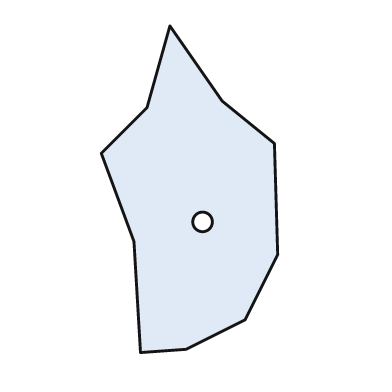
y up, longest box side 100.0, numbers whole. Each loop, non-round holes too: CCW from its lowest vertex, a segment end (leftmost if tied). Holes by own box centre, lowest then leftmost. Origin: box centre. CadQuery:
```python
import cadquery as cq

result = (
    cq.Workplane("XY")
    .moveTo(-15.0, -50.0)
    .lineTo(-1.0, -49.0)
    .lineTo(17.0, -40.0)
    .lineTo(27.0, -20.0)
    .lineTo(26.0, 14.0)
    .lineTo(10.0, 27.0)
    .lineTo(-6.0, 50.0)
    .lineTo(-13.0, 25.0)
    .lineTo(-27.0, 11.0)
    .lineTo(-17.0, -16.0)
    .close()
    .moveTo(4.0, -10.0)
    .circle(3.0)
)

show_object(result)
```